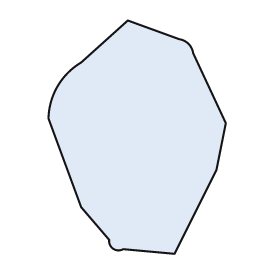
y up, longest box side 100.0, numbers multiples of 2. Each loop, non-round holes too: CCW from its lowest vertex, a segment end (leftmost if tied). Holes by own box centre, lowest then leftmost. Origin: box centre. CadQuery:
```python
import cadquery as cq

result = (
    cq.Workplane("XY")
    .moveTo(16.0, -50.0)
    .lineTo(34.0, -14.0)
    .lineTo(38.0, 6.0)
    .lineTo(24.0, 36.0)
    .threePointArc((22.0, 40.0), (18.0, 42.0))
    .lineTo(-4.0, 50.0)
    .lineTo(-24.0, 32.0)
    .threePointArc((-34.0, 22.0), (-38.0, 8.0))
    .lineTo(-24.0, -30.0)
    .lineTo(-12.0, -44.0)
    .threePointArc((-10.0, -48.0), (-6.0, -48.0))
    .close()
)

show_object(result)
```